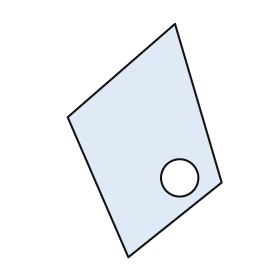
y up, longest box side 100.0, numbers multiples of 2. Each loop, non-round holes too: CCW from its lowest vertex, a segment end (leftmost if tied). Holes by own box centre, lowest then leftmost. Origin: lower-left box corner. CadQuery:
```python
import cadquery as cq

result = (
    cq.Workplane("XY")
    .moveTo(26.0, 0.0)
    .lineTo(66.0, 32.0)
    .lineTo(46.0, 100.0)
    .lineTo(0.0, 60.0)
    .close()
    .moveTo(48.0, 34.0)
    .circle(8.0)
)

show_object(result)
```